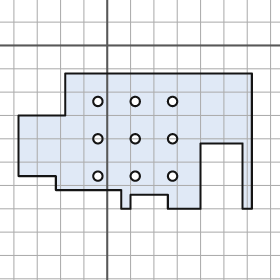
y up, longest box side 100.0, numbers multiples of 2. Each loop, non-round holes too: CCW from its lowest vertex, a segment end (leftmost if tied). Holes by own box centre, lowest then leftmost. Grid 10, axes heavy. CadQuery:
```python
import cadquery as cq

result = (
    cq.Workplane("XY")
    .moveTo(6.0, -70.0)
    .lineTo(10.0, -70.0)
    .lineTo(10.0, -64.0)
    .lineTo(26.0, -64.0)
    .lineTo(26.0, -70.0)
    .lineTo(40.0, -70.0)
    .lineTo(40.0, -42.0)
    .lineTo(58.0, -42.0)
    .lineTo(58.0, -70.0)
    .lineTo(62.0, -70.0)
    .lineTo(62.0, -12.0)
    .lineTo(-18.0, -12.0)
    .lineTo(-18.0, -30.0)
    .lineTo(-38.0, -30.0)
    .lineTo(-38.0, -56.0)
    .lineTo(-22.0, -56.0)
    .lineTo(-22.0, -62.0)
    .lineTo(6.0, -62.0)
    .close()
    .moveTo(-4.0, -56.0)
    .circle(2.0)
    .moveTo(12.0, -56.0)
    .circle(2.0)
    .moveTo(28.0, -56.0)
    .circle(2.0)
    .moveTo(-4.0, -40.0)
    .circle(2.0)
    .moveTo(12.0, -40.0)
    .circle(2.0)
    .moveTo(28.0, -40.0)
    .circle(2.0)
    .moveTo(-4.0, -24.0)
    .circle(2.0)
    .moveTo(12.0, -24.0)
    .circle(2.0)
    .moveTo(28.0, -24.0)
    .circle(2.0)
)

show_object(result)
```